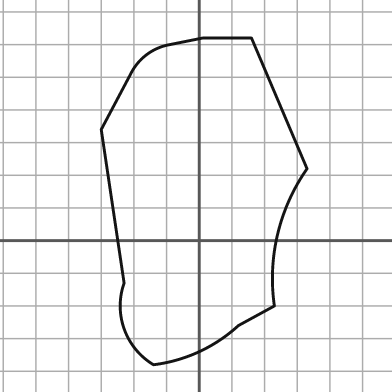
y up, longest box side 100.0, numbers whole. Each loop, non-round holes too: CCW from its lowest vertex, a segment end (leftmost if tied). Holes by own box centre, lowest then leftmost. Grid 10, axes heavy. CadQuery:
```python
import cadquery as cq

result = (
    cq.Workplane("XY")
    .moveTo(-14.0, -38.0)
    .threePointArc((0.0, -34.0), (12.0, -26.0))
    .lineTo(23.0, -20.0)
    .threePointArc((24.0, 2.0), (33.0, 22.0))
    .lineTo(16.0, 62.0)
    .lineTo(1.0, 62.0)
    .lineTo(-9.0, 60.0)
    .threePointArc((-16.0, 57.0), (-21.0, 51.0))
    .lineTo(-30.0, 34.0)
    .lineTo(-23.0, -13.0)
    .threePointArc((-23.0, -27.0), (-14.0, -38.0))
    .close()
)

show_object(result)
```